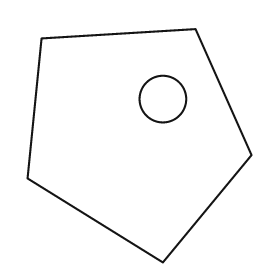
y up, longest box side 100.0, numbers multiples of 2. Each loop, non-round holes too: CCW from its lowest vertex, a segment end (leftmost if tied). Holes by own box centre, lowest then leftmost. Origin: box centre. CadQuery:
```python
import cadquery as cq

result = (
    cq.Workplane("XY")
    .moveTo(10.0, -50.0)
    .lineTo(48.0, -4.0)
    .lineTo(24.0, 50.0)
    .lineTo(-42.0, 46.0)
    .lineTo(-48.0, -14.0)
    .close()
    .moveTo(10.0, 20.0)
    .circle(10.0)
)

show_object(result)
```